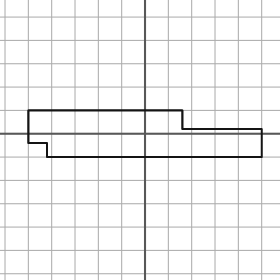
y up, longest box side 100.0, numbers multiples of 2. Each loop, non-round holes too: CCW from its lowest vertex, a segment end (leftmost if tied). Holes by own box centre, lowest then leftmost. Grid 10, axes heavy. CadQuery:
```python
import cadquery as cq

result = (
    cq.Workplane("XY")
    .moveTo(-42.0, -10.0)
    .lineTo(50.0, -10.0)
    .lineTo(50.0, 2.0)
    .lineTo(16.0, 2.0)
    .lineTo(16.0, 10.0)
    .lineTo(-50.0, 10.0)
    .lineTo(-50.0, -4.0)
    .lineTo(-42.0, -4.0)
    .close()
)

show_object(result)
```